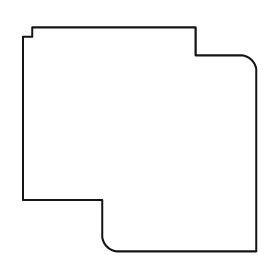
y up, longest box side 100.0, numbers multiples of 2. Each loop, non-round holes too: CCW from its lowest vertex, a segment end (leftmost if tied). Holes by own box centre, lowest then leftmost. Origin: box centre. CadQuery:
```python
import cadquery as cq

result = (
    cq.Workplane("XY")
    .moveTo(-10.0, -48.0)
    .lineTo(50.0, -48.0)
    .lineTo(50.0, 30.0)
    .threePointArc((48.0, 34.0), (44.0, 36.0))
    .lineTo(24.0, 36.0)
    .lineTo(24.0, 48.0)
    .lineTo(-46.0, 48.0)
    .lineTo(-46.0, 44.0)
    .lineTo(-50.0, 44.0)
    .lineTo(-50.0, -26.0)
    .lineTo(-16.0, -26.0)
    .lineTo(-16.0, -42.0)
    .threePointArc((-14.0, -46.0), (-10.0, -48.0))
    .close()
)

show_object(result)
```